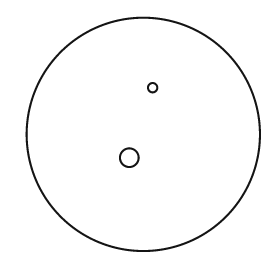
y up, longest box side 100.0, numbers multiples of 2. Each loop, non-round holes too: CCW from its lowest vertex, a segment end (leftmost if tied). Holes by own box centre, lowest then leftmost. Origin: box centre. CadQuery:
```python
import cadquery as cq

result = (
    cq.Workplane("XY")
    .moveTo(0.0, 0.0)
    .circle(50.0)
    .moveTo(-6.0, -10.0)
    .circle(4.0)
    .moveTo(4.0, 20.0)
    .circle(2.0)
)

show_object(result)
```